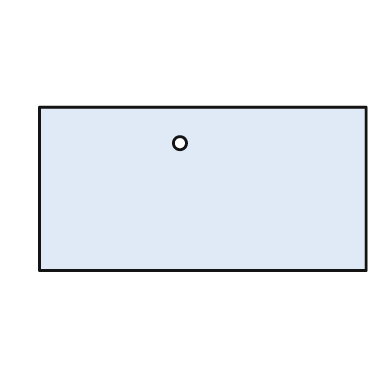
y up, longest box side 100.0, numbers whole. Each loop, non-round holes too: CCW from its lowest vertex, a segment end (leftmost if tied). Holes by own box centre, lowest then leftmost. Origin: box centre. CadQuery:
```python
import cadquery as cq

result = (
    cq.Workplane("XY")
    .moveTo(-50.0, -25.0)
    .lineTo(50.0, -25.0)
    .lineTo(50.0, 25.0)
    .lineTo(-50.0, 25.0)
    .close()
    .moveTo(-7.0, 14.0)
    .circle(2.0)
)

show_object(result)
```